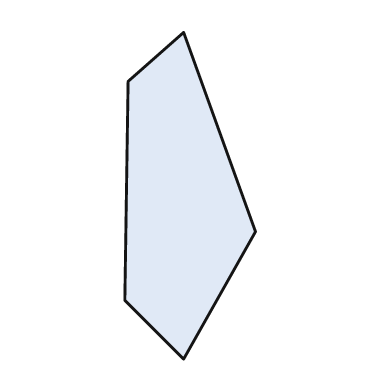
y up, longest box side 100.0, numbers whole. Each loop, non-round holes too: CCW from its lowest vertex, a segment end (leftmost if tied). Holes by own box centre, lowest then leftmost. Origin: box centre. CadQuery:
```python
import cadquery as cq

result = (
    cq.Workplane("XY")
    .moveTo(-2.0, -50.0)
    .lineTo(20.0, -11.0)
    .lineTo(-2.0, 50.0)
    .lineTo(-19.0, 35.0)
    .lineTo(-20.0, -32.0)
    .close()
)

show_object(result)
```